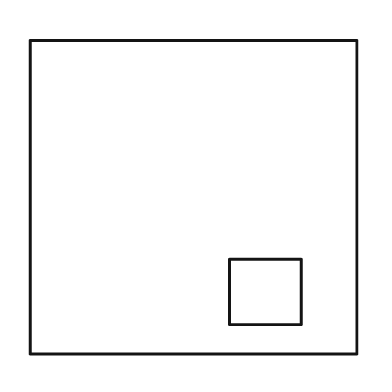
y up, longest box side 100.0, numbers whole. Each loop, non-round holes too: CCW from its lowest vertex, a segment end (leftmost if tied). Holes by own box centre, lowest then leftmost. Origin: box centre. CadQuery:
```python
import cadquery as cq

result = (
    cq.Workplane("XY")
    .moveTo(-50.0, -48.0)
    .lineTo(50.0, -48.0)
    .lineTo(50.0, 48.0)
    .lineTo(-50.0, 48.0)
    .close()
    .moveTo(11.0, -39.0)
    .lineTo(33.0, -39.0)
    .lineTo(33.0, -19.0)
    .lineTo(11.0, -19.0)
    .close()
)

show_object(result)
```